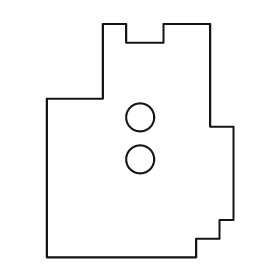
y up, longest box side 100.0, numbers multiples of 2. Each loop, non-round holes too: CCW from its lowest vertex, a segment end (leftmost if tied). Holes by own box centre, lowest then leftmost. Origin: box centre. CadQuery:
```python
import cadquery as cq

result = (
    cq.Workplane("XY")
    .moveTo(-40.0, -50.0)
    .lineTo(24.0, -50.0)
    .lineTo(24.0, -42.0)
    .lineTo(34.0, -42.0)
    .lineTo(34.0, -34.0)
    .lineTo(40.0, -34.0)
    .lineTo(40.0, 6.0)
    .lineTo(30.0, 6.0)
    .lineTo(30.0, 50.0)
    .lineTo(10.0, 50.0)
    .lineTo(10.0, 42.0)
    .lineTo(-6.0, 42.0)
    .lineTo(-6.0, 50.0)
    .lineTo(-16.0, 50.0)
    .lineTo(-16.0, 18.0)
    .lineTo(-40.0, 18.0)
    .close()
    .moveTo(0.0, -8.0)
    .circle(6.0)
    .moveTo(0.0, 10.0)
    .circle(6.0)
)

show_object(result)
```